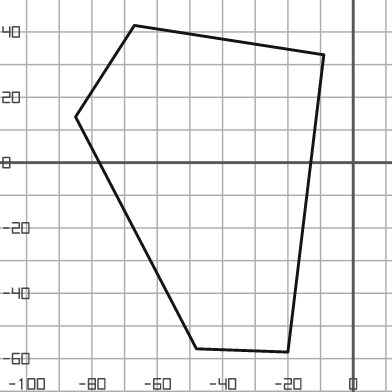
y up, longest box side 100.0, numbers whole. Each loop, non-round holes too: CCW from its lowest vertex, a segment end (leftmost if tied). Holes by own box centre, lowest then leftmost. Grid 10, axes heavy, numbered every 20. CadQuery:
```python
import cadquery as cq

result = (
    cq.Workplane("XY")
    .moveTo(-20.0, -58.0)
    .lineTo(-9.0, 33.0)
    .lineTo(-67.0, 42.0)
    .lineTo(-85.0, 14.0)
    .lineTo(-48.0, -57.0)
    .close()
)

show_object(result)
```